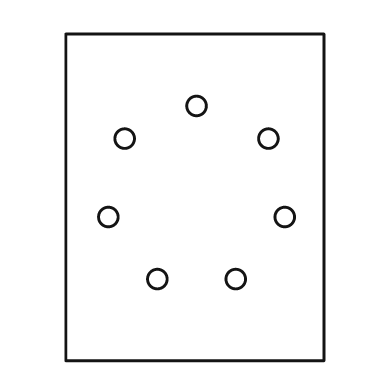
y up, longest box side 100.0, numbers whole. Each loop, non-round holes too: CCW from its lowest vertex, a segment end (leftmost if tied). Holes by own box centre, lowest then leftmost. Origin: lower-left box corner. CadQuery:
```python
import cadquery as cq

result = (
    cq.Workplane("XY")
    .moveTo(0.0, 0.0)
    .lineTo(79.0, 0.0)
    .lineTo(79.0, 100.0)
    .lineTo(0.0, 100.0)
    .close()
    .moveTo(28.0, 25.0)
    .circle(3.0)
    .moveTo(52.0, 25.0)
    .circle(3.0)
    .moveTo(13.0, 44.0)
    .circle(3.0)
    .moveTo(67.0, 44.0)
    .circle(3.0)
    .moveTo(18.0, 68.0)
    .circle(3.0)
    .moveTo(62.0, 68.0)
    .circle(3.0)
    .moveTo(40.0, 78.0)
    .circle(3.0)
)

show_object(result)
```